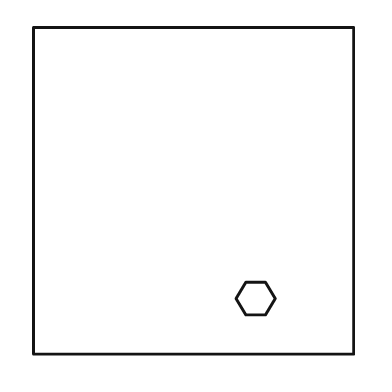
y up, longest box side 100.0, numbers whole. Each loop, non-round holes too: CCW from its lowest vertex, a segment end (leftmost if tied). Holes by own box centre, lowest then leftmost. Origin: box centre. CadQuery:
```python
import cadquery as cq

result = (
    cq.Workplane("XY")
    .moveTo(-49.0, -50.0)
    .lineTo(49.0, -50.0)
    .lineTo(49.0, 50.0)
    .lineTo(-49.0, 50.0)
    .close()
    .moveTo(16.0, -38.0)
    .lineTo(22.0, -38.0)
    .lineTo(25.0, -33.0)
    .lineTo(22.0, -28.0)
    .lineTo(16.0, -28.0)
    .lineTo(13.0, -33.0)
    .close()
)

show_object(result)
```